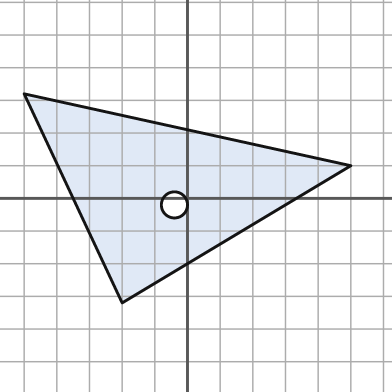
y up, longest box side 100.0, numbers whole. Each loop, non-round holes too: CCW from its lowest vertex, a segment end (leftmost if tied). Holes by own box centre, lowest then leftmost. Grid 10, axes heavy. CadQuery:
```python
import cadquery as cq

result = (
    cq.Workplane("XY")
    .moveTo(-20.0, -32.0)
    .lineTo(50.0, 10.0)
    .lineTo(-50.0, 32.0)
    .close()
    .moveTo(-4.0, -2.0)
    .circle(4.0)
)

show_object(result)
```